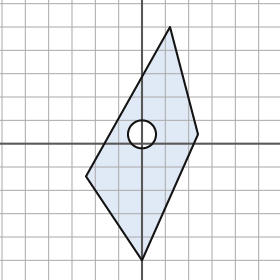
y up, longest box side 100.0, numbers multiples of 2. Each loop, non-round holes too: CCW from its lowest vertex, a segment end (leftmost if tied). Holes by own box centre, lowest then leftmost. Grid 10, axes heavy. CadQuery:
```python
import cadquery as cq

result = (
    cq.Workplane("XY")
    .moveTo(0.0, -50.0)
    .lineTo(24.0, 4.0)
    .lineTo(12.0, 50.0)
    .lineTo(-24.0, -14.0)
    .close()
    .moveTo(0.0, 4.0)
    .circle(6.0)
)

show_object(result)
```